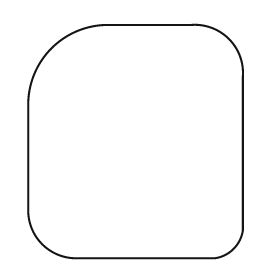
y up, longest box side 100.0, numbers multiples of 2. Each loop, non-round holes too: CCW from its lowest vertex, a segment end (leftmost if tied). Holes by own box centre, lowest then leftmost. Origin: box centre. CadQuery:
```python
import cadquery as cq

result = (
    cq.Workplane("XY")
    .moveTo(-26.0, -50.0)
    .lineTo(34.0, -50.0)
    .threePointArc((42.0, -46.0), (46.0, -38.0))
    .lineTo(46.0, 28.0)
    .threePointArc((40.0, 44.0), (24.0, 50.0))
    .lineTo(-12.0, 50.0)
    .threePointArc((-36.0, 40.0), (-46.0, 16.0))
    .lineTo(-46.0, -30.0)
    .threePointArc((-40.0, -44.0), (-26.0, -50.0))
    .close()
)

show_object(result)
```